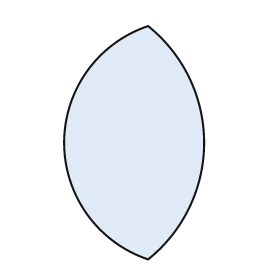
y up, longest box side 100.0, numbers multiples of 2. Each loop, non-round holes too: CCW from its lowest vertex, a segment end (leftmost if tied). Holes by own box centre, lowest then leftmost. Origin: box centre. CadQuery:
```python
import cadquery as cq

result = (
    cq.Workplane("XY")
    .moveTo(6.0, -50.0)
    .threePointArc((30.0, 0.0), (6.0, 50.0))
    .threePointArc((-30.0, 0.0), (6.0, -50.0))
    .close()
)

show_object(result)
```